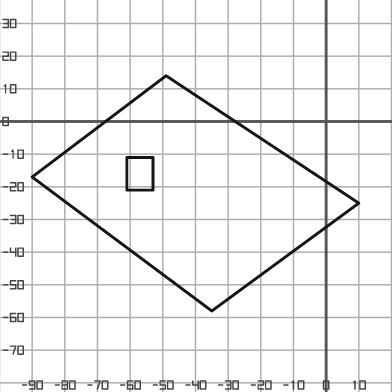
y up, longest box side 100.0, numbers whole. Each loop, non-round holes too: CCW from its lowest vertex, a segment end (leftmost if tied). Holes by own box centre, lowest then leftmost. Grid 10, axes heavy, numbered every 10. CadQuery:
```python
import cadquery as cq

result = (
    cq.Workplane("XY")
    .moveTo(-35.0, -58.0)
    .lineTo(10.0, -25.0)
    .lineTo(-49.0, 14.0)
    .lineTo(-90.0, -17.0)
    .close()
    .moveTo(-61.0, -21.0)
    .lineTo(-53.0, -21.0)
    .lineTo(-53.0, -11.0)
    .lineTo(-61.0, -11.0)
    .close()
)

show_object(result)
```